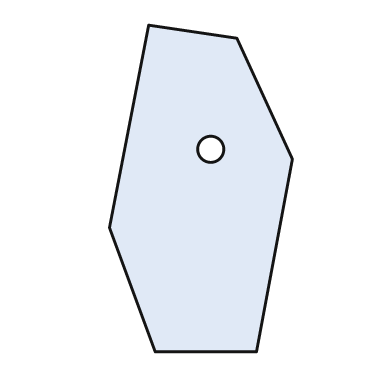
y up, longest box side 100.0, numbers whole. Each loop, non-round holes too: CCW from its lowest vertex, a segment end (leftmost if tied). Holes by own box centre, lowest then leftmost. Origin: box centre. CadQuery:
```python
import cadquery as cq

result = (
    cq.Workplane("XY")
    .moveTo(-14.0, -50.0)
    .lineTo(17.0, -50.0)
    .lineTo(28.0, 9.0)
    .lineTo(11.0, 46.0)
    .lineTo(-16.0, 50.0)
    .lineTo(-28.0, -12.0)
    .close()
    .moveTo(3.0, 12.0)
    .circle(4.0)
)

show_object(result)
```